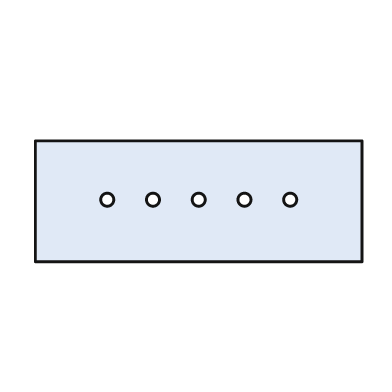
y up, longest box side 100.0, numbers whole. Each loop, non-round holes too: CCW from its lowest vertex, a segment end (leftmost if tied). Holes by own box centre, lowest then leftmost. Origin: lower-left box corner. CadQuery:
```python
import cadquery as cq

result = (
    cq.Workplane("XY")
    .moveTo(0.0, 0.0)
    .lineTo(100.0, 0.0)
    .lineTo(100.0, 37.0)
    .lineTo(0.0, 37.0)
    .close()
    .moveTo(22.0, 19.0)
    .circle(2.0)
    .moveTo(36.0, 19.0)
    .circle(2.0)
    .moveTo(50.0, 19.0)
    .circle(2.0)
    .moveTo(64.0, 19.0)
    .circle(2.0)
    .moveTo(78.0, 19.0)
    .circle(2.0)
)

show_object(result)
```